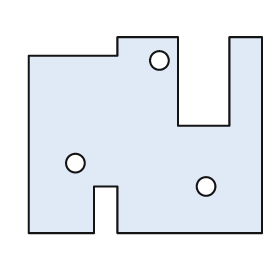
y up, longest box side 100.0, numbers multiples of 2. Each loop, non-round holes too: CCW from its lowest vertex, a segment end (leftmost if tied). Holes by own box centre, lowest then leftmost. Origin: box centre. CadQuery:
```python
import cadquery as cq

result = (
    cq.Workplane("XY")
    .moveTo(-50.0, -42.0)
    .lineTo(-22.0, -42.0)
    .lineTo(-22.0, -22.0)
    .lineTo(-12.0, -22.0)
    .lineTo(-12.0, -42.0)
    .lineTo(50.0, -42.0)
    .lineTo(50.0, 42.0)
    .lineTo(36.0, 42.0)
    .lineTo(36.0, 4.0)
    .lineTo(14.0, 4.0)
    .lineTo(14.0, 42.0)
    .lineTo(-12.0, 42.0)
    .lineTo(-12.0, 34.0)
    .lineTo(-50.0, 34.0)
    .close()
    .moveTo(26.0, -22.0)
    .circle(4.0)
    .moveTo(-30.0, -12.0)
    .circle(4.0)
    .moveTo(6.0, 32.0)
    .circle(4.0)
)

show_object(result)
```